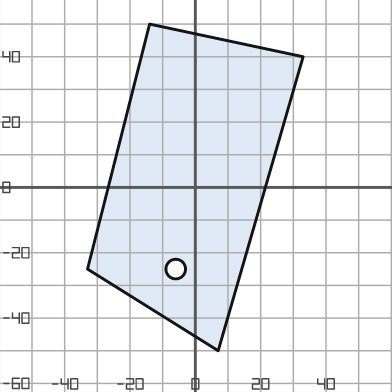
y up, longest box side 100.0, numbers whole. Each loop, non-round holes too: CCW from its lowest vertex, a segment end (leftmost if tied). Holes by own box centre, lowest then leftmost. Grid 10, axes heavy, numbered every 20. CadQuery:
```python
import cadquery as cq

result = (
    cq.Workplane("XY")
    .moveTo(7.0, -50.0)
    .lineTo(33.0, 40.0)
    .lineTo(-14.0, 50.0)
    .lineTo(-33.0, -25.0)
    .close()
    .moveTo(-6.0, -25.0)
    .circle(3.0)
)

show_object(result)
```